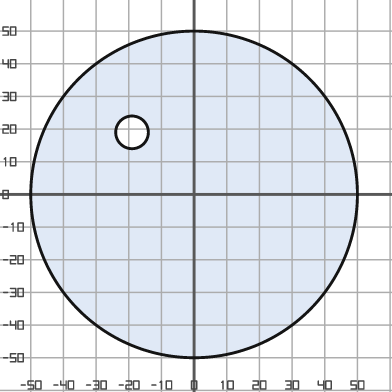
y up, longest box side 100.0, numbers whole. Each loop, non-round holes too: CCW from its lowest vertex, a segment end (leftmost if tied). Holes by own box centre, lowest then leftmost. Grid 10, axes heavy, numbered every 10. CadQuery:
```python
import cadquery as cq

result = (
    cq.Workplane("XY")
    .moveTo(0.0, 0.0)
    .circle(50.0)
    .moveTo(-19.0, 19.0)
    .circle(5.0)
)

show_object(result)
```